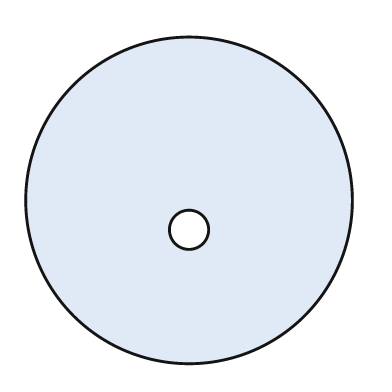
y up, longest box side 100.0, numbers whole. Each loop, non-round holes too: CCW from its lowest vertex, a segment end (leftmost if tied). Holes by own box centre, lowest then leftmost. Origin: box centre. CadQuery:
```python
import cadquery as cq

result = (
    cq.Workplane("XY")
    .moveTo(0.0, 0.0)
    .circle(50.0)
    .moveTo(0.0, -9.0)
    .circle(6.0)
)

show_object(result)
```